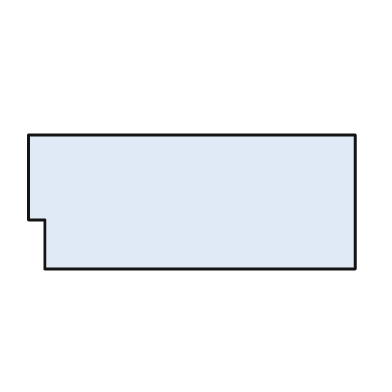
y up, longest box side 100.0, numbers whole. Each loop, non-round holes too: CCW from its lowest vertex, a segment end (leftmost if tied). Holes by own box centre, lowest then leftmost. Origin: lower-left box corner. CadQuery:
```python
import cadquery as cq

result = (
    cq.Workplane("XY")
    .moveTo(5.0, 0.0)
    .lineTo(100.0, 0.0)
    .lineTo(100.0, 41.0)
    .lineTo(0.0, 41.0)
    .lineTo(0.0, 15.0)
    .lineTo(5.0, 15.0)
    .close()
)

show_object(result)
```